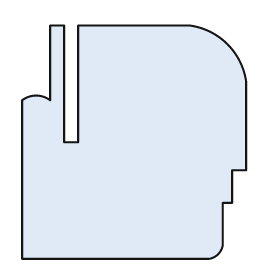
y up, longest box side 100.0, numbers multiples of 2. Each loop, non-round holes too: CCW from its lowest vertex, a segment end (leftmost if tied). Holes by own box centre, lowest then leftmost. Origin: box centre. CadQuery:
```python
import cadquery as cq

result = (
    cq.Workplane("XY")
    .moveTo(-48.0, -50.0)
    .lineTo(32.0, -50.0)
    .threePointArc((36.0, -48.0), (38.0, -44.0))
    .lineTo(38.0, -26.0)
    .lineTo(42.0, -26.0)
    .lineTo(42.0, -12.0)
    .lineTo(48.0, -12.0)
    .lineTo(48.0, 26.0)
    .threePointArc((40.0, 42.0), (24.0, 50.0))
    .lineTo(-24.0, 50.0)
    .lineTo(-24.0, 0.0)
    .lineTo(-30.0, 0.0)
    .lineTo(-30.0, 50.0)
    .lineTo(-36.0, 50.0)
    .lineTo(-36.0, 18.0)
    .threePointArc((-42.0, 20.0), (-48.0, 18.0))
    .close()
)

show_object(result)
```